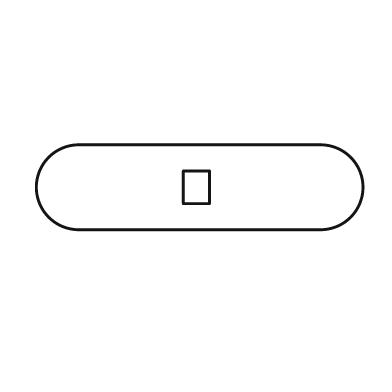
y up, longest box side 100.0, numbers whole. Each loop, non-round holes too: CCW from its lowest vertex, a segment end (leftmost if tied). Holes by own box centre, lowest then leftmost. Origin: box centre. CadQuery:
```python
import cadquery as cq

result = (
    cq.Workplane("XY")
    .moveTo(-37.0, -13.0)
    .lineTo(37.0, -13.0)
    .threePointArc((50.0, 0.0), (37.0, 13.0))
    .lineTo(-37.0, 13.0)
    .threePointArc((-50.0, 0.0), (-37.0, -13.0))
    .close()
    .moveTo(-5.0, -5.0)
    .lineTo(3.0, -5.0)
    .lineTo(3.0, 5.0)
    .lineTo(-5.0, 5.0)
    .close()
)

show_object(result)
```